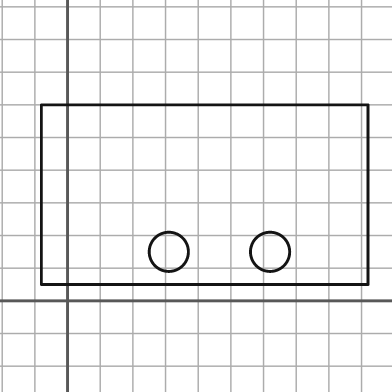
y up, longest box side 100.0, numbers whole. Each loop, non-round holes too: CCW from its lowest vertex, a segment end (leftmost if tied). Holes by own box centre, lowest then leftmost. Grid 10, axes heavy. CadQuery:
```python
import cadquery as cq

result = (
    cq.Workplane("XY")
    .moveTo(-8.0, 5.0)
    .lineTo(92.0, 5.0)
    .lineTo(92.0, 60.0)
    .lineTo(-8.0, 60.0)
    .close()
    .moveTo(31.0, 15.0)
    .circle(6.0)
    .moveTo(62.0, 15.0)
    .circle(6.0)
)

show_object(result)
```